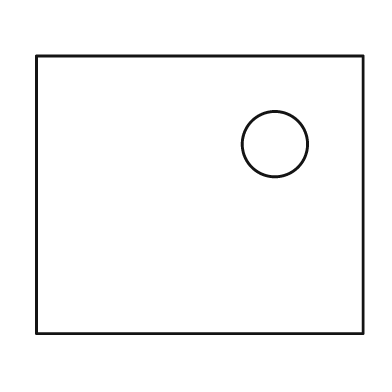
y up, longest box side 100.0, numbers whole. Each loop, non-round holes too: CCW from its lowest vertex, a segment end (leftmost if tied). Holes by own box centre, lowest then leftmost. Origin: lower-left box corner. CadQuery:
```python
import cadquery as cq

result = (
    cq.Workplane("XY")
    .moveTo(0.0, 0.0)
    .lineTo(100.0, 0.0)
    .lineTo(100.0, 85.0)
    .lineTo(0.0, 85.0)
    .close()
    .moveTo(73.0, 58.0)
    .circle(10.0)
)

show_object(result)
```